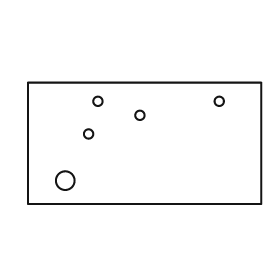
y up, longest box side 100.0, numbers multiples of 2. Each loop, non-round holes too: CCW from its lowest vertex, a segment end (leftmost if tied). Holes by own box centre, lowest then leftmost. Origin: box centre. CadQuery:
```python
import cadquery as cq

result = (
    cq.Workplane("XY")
    .moveTo(-50.0, -26.0)
    .lineTo(50.0, -26.0)
    .lineTo(50.0, 26.0)
    .lineTo(-50.0, 26.0)
    .close()
    .moveTo(-34.0, -16.0)
    .circle(4.0)
    .moveTo(-24.0, 4.0)
    .circle(2.0)
    .moveTo(-2.0, 12.0)
    .circle(2.0)
    .moveTo(-20.0, 18.0)
    .circle(2.0)
    .moveTo(32.0, 18.0)
    .circle(2.0)
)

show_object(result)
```